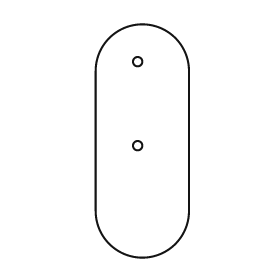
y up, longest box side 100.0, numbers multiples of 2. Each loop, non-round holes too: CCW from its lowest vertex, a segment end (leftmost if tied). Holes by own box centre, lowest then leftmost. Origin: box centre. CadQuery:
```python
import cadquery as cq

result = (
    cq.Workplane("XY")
    .moveTo(-20.0, -30.0)
    .threePointArc((0.0, -50.0), (20.0, -30.0))
    .lineTo(20.0, 30.0)
    .threePointArc((0.0, 50.0), (-20.0, 30.0))
    .close()
    .moveTo(-2.0, -2.0)
    .circle(2.0)
    .moveTo(-2.0, 34.0)
    .circle(2.0)
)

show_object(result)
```